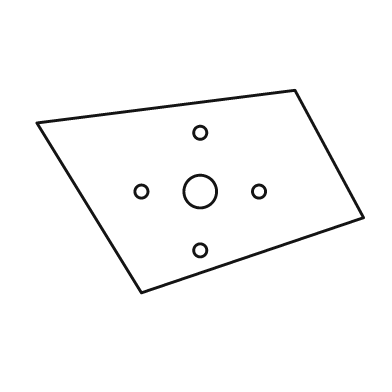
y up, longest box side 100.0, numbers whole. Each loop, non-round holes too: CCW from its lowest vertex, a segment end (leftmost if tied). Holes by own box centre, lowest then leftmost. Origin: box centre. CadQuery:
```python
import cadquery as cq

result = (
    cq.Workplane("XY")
    .moveTo(-18.0, -31.0)
    .lineTo(50.0, -8.0)
    .lineTo(29.0, 31.0)
    .lineTo(-50.0, 21.0)
    .close()
    .moveTo(0.0, -18.0)
    .circle(2.0)
    .moveTo(-18.0, 0.0)
    .circle(2.0)
    .moveTo(0.0, 0.0)
    .circle(5.0)
    .moveTo(18.0, 0.0)
    .circle(2.0)
    .moveTo(0.0, 18.0)
    .circle(2.0)
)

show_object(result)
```